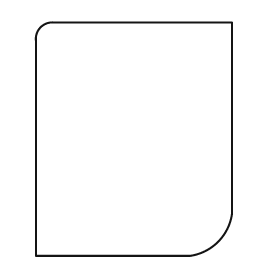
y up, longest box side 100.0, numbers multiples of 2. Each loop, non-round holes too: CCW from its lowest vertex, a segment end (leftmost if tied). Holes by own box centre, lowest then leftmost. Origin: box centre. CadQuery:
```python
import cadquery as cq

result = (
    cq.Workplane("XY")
    .moveTo(-42.0, -50.0)
    .lineTo(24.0, -50.0)
    .threePointArc((36.0, -44.0), (42.0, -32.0))
    .lineTo(42.0, 50.0)
    .lineTo(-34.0, 50.0)
    .threePointArc((-40.0, 48.0), (-42.0, 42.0))
    .close()
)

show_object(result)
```